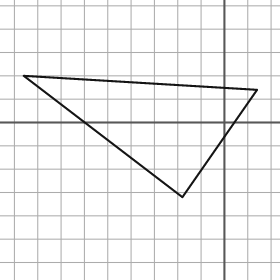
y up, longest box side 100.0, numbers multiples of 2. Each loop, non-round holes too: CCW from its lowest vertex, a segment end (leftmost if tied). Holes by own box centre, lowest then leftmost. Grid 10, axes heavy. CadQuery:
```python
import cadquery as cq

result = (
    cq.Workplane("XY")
    .moveTo(-18.0, -32.0)
    .lineTo(14.0, 14.0)
    .lineTo(-86.0, 20.0)
    .close()
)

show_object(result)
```